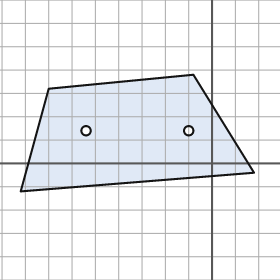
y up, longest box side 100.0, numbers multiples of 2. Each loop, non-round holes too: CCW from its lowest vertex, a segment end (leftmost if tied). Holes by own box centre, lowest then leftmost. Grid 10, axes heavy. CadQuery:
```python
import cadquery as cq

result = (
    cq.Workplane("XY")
    .moveTo(-82.0, -12.0)
    .lineTo(18.0, -4.0)
    .lineTo(-8.0, 38.0)
    .lineTo(-70.0, 32.0)
    .close()
    .moveTo(-54.0, 14.0)
    .circle(2.0)
    .moveTo(-10.0, 14.0)
    .circle(2.0)
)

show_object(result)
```